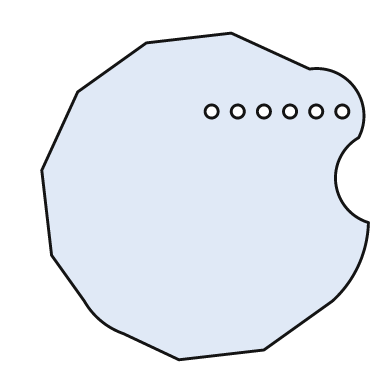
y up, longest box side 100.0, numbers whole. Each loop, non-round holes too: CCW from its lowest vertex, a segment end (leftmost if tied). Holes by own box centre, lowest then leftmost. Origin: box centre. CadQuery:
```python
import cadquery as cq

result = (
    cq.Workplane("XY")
    .moveTo(-8.0, -50.0)
    .lineTo(18.0, -47.0)
    .lineTo(39.0, -32.0)
    .threePointArc((47.0, -21.0), (50.0, -8.0))
    .threePointArc((40.0, 4.0), (47.0, 18.0))
    .threePointArc((46.0, 33.0), (32.0, 39.0))
    .lineTo(8.0, 50.0)
    .lineTo(-18.0, 47.0)
    .lineTo(-39.0, 32.0)
    .lineTo(-50.0, 8.0)
    .lineTo(-47.0, -18.0)
    .lineTo(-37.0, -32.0)
    .threePointArc((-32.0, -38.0), (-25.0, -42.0))
    .close()
    .moveTo(2.0, 26.0)
    .circle(2.0)
    .moveTo(10.0, 26.0)
    .circle(2.0)
    .moveTo(18.0, 26.0)
    .circle(2.0)
    .moveTo(26.0, 26.0)
    .circle(2.0)
    .moveTo(34.0, 26.0)
    .circle(2.0)
    .moveTo(42.0, 26.0)
    .circle(2.0)
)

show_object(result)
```